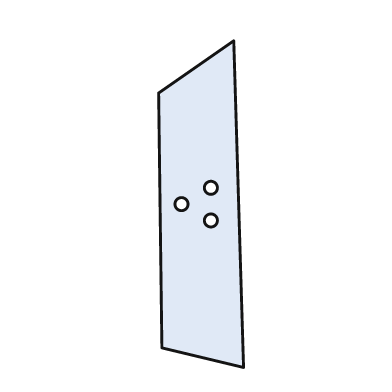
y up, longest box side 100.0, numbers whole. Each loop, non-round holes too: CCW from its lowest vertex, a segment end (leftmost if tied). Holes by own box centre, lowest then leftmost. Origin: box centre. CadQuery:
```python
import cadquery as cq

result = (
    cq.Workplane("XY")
    .moveTo(13.0, -50.0)
    .lineTo(10.0, 50.0)
    .lineTo(-13.0, 34.0)
    .lineTo(-12.0, -44.0)
    .close()
    .moveTo(3.0, -5.0)
    .circle(2.0)
    .moveTo(-6.0, 0.0)
    .circle(2.0)
    .moveTo(3.0, 5.0)
    .circle(2.0)
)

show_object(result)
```